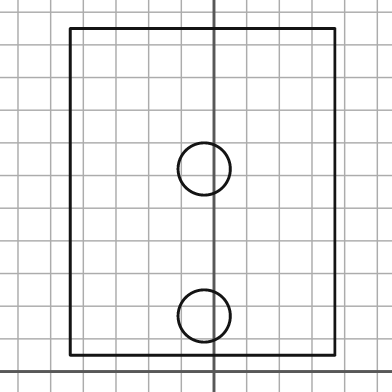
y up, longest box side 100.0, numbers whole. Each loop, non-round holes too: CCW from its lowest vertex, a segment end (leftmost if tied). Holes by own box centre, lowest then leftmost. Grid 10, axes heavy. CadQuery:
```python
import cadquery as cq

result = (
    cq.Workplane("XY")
    .moveTo(-44.0, 5.0)
    .lineTo(37.0, 5.0)
    .lineTo(37.0, 105.0)
    .lineTo(-44.0, 105.0)
    .close()
    .moveTo(-3.0, 17.0)
    .circle(8.0)
    .moveTo(-3.0, 62.0)
    .circle(8.0)
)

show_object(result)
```